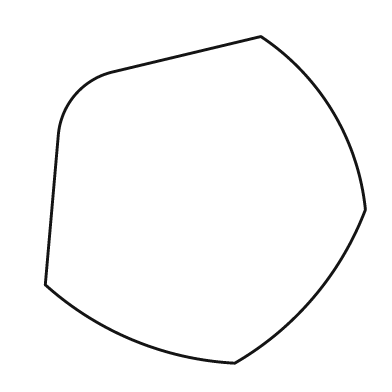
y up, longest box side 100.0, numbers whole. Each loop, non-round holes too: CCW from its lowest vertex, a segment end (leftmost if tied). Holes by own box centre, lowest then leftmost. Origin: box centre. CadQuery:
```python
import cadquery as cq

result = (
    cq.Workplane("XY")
    .moveTo(9.0, -50.0)
    .threePointArc((33.0, -30.0), (49.0, -3.0))
    .threePointArc((39.0, 27.0), (17.0, 50.0))
    .lineTo(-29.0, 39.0)
    .threePointArc((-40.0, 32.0), (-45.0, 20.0))
    .lineTo(-49.0, -26.0)
    .threePointArc((-22.0, -43.0), (9.0, -50.0))
    .close()
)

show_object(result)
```